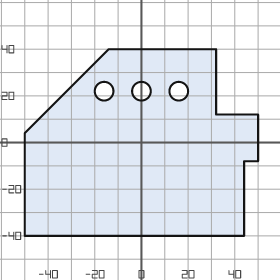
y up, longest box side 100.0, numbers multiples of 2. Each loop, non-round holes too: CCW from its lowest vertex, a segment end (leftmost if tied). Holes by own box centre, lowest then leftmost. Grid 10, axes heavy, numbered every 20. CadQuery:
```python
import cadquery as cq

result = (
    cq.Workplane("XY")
    .moveTo(-50.0, -40.0)
    .lineTo(44.0, -40.0)
    .lineTo(44.0, -8.0)
    .lineTo(50.0, -8.0)
    .lineTo(50.0, 12.0)
    .lineTo(32.0, 12.0)
    .lineTo(32.0, 40.0)
    .lineTo(-14.0, 40.0)
    .lineTo(-50.0, 4.0)
    .close()
    .moveTo(-16.0, 22.0)
    .circle(4.0)
    .moveTo(0.0, 22.0)
    .circle(4.0)
    .moveTo(16.0, 22.0)
    .circle(4.0)
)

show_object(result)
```